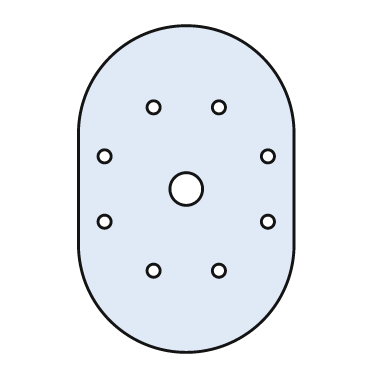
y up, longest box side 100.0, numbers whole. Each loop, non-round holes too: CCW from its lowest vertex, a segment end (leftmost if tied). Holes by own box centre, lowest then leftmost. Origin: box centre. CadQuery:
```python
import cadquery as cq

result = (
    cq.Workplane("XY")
    .moveTo(-33.0, -17.0)
    .threePointArc((0.0, -50.0), (33.0, -17.0))
    .lineTo(33.0, 17.0)
    .threePointArc((0.0, 50.0), (-33.0, 17.0))
    .close()
    .moveTo(-10.0, -25.0)
    .circle(2.0)
    .moveTo(10.0, -25.0)
    .circle(2.0)
    .moveTo(-25.0, -10.0)
    .circle(2.0)
    .moveTo(25.0, -10.0)
    .circle(2.0)
    .moveTo(0.0, 0.0)
    .circle(5.0)
    .moveTo(-25.0, 10.0)
    .circle(2.0)
    .moveTo(25.0, 10.0)
    .circle(2.0)
    .moveTo(-10.0, 25.0)
    .circle(2.0)
    .moveTo(10.0, 25.0)
    .circle(2.0)
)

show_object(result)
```